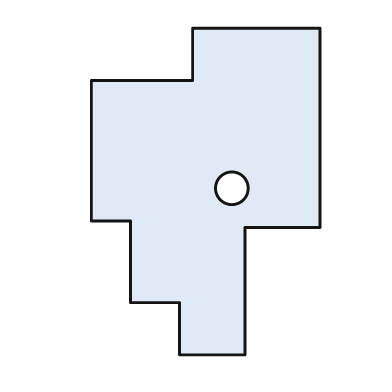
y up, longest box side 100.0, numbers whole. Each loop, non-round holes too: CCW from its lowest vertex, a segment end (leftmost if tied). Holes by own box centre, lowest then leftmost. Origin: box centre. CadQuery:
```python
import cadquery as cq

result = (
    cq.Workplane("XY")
    .moveTo(-8.0, -50.0)
    .lineTo(12.0, -50.0)
    .lineTo(12.0, -11.0)
    .lineTo(35.0, -11.0)
    .lineTo(35.0, 50.0)
    .lineTo(-4.0, 50.0)
    .lineTo(-4.0, 34.0)
    .lineTo(-35.0, 34.0)
    .lineTo(-35.0, -9.0)
    .lineTo(-23.0, -9.0)
    .lineTo(-23.0, -34.0)
    .lineTo(-8.0, -34.0)
    .close()
    .moveTo(8.0, 1.0)
    .circle(5.0)
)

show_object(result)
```